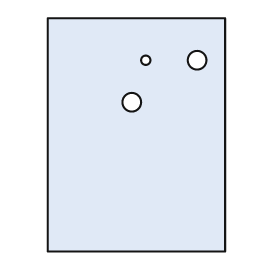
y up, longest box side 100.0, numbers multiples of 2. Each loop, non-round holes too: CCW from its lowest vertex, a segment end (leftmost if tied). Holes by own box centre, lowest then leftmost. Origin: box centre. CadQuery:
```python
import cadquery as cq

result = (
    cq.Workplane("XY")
    .moveTo(-38.0, -50.0)
    .lineTo(38.0, -50.0)
    .lineTo(38.0, 50.0)
    .lineTo(-38.0, 50.0)
    .close()
    .moveTo(-2.0, 14.0)
    .circle(4.0)
    .moveTo(4.0, 32.0)
    .circle(2.0)
    .moveTo(26.0, 32.0)
    .circle(4.0)
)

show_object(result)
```